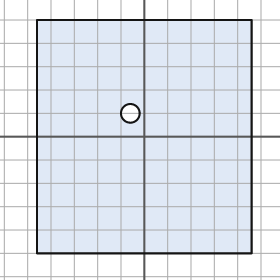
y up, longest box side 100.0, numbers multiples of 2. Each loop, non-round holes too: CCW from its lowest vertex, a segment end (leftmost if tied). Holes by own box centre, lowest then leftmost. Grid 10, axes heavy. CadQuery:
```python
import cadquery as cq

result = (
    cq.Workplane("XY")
    .moveTo(-46.0, -50.0)
    .lineTo(46.0, -50.0)
    .lineTo(46.0, 50.0)
    .lineTo(-46.0, 50.0)
    .close()
    .moveTo(-6.0, 10.0)
    .circle(4.0)
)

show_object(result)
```